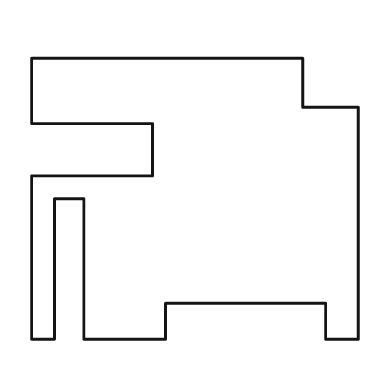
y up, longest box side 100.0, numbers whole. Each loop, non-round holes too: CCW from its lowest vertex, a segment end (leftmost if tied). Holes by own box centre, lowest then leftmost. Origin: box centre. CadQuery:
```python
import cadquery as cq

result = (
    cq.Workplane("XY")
    .moveTo(-50.0, -43.0)
    .lineTo(-43.0, -43.0)
    .lineTo(-43.0, 0.0)
    .lineTo(-34.0, 0.0)
    .lineTo(-34.0, -43.0)
    .lineTo(-9.0, -43.0)
    .lineTo(-9.0, -32.0)
    .lineTo(40.0, -32.0)
    .lineTo(40.0, -43.0)
    .lineTo(50.0, -43.0)
    .lineTo(50.0, 28.0)
    .lineTo(33.0, 28.0)
    .lineTo(33.0, 43.0)
    .lineTo(-50.0, 43.0)
    .lineTo(-50.0, 23.0)
    .lineTo(-13.0, 23.0)
    .lineTo(-13.0, 7.0)
    .lineTo(-50.0, 7.0)
    .close()
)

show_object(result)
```